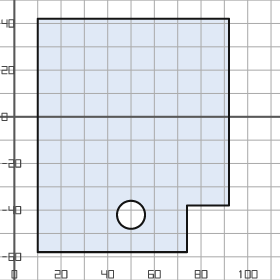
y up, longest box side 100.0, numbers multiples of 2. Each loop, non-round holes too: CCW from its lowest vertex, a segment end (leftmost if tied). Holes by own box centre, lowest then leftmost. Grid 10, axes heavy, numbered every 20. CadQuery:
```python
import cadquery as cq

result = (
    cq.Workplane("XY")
    .moveTo(10.0, -58.0)
    .lineTo(74.0, -58.0)
    .lineTo(74.0, -38.0)
    .lineTo(92.0, -38.0)
    .lineTo(92.0, 42.0)
    .lineTo(10.0, 42.0)
    .close()
    .moveTo(50.0, -42.0)
    .circle(6.0)
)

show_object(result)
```